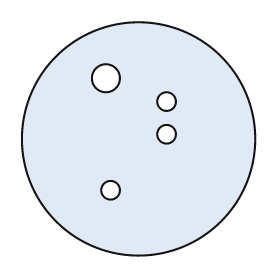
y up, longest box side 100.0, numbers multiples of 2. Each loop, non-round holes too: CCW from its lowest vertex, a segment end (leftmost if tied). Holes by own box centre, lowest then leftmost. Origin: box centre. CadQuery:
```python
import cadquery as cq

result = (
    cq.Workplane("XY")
    .moveTo(0.0, 0.0)
    .circle(50.0)
    .moveTo(-12.0, -22.0)
    .circle(4.0)
    .moveTo(12.0, 2.0)
    .circle(4.0)
    .moveTo(12.0, 16.0)
    .circle(4.0)
    .moveTo(-14.0, 26.0)
    .circle(6.0)
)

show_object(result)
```